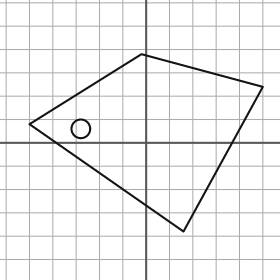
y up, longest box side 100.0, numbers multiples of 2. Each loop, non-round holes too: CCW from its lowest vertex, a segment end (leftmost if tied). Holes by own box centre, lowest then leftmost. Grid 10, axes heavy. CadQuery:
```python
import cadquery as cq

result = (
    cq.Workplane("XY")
    .moveTo(16.0, -38.0)
    .lineTo(50.0, 24.0)
    .lineTo(-2.0, 38.0)
    .lineTo(-50.0, 8.0)
    .close()
    .moveTo(-28.0, 6.0)
    .circle(4.0)
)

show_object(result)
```